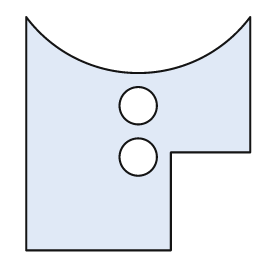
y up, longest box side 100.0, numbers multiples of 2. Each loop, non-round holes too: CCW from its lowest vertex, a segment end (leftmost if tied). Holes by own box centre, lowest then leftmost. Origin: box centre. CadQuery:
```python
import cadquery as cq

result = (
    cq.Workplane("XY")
    .moveTo(-48.0, -50.0)
    .lineTo(14.0, -50.0)
    .lineTo(14.0, -8.0)
    .lineTo(48.0, -8.0)
    .lineTo(48.0, 50.0)
    .threePointArc((0.0, 26.0), (-48.0, 50.0))
    .close()
    .moveTo(0.0, -10.0)
    .circle(8.0)
    .moveTo(0.0, 12.0)
    .circle(8.0)
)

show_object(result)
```